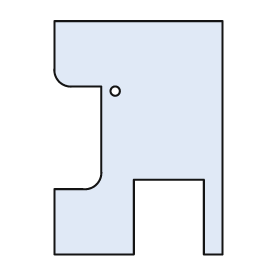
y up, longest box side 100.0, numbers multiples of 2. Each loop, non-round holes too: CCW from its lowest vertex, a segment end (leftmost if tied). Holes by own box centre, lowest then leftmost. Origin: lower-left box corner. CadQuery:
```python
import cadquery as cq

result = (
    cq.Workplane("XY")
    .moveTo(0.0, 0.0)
    .lineTo(34.0, 0.0)
    .lineTo(34.0, 32.0)
    .lineTo(64.0, 32.0)
    .lineTo(64.0, 0.0)
    .lineTo(72.0, 0.0)
    .lineTo(72.0, 100.0)
    .lineTo(0.0, 100.0)
    .lineTo(0.0, 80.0)
    .threePointArc((2.0, 74.0), (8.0, 72.0))
    .lineTo(20.0, 72.0)
    .lineTo(20.0, 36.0)
    .threePointArc((18.0, 30.0), (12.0, 28.0))
    .lineTo(0.0, 28.0)
    .close()
    .moveTo(26.0, 70.0)
    .circle(2.0)
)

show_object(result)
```